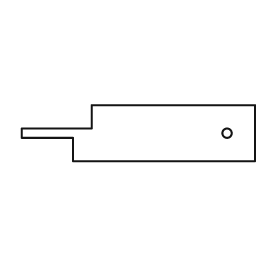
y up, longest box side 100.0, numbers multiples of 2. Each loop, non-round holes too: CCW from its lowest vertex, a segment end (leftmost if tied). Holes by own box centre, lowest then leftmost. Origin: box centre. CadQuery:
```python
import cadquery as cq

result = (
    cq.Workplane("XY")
    .moveTo(-28.0, -12.0)
    .lineTo(50.0, -12.0)
    .lineTo(50.0, 12.0)
    .lineTo(-20.0, 12.0)
    .lineTo(-20.0, 2.0)
    .lineTo(-50.0, 2.0)
    .lineTo(-50.0, -2.0)
    .lineTo(-28.0, -2.0)
    .close()
    .moveTo(38.0, 0.0)
    .circle(2.0)
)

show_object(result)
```